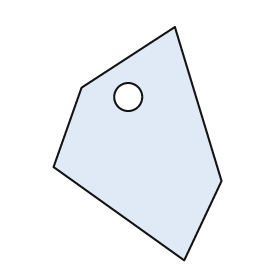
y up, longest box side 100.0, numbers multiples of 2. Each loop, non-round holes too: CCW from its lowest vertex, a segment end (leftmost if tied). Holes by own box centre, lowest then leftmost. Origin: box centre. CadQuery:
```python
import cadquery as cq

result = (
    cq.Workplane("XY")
    .moveTo(20.0, -50.0)
    .lineTo(36.0, -16.0)
    .lineTo(16.0, 50.0)
    .lineTo(-24.0, 24.0)
    .lineTo(-36.0, -10.0)
    .close()
    .moveTo(-4.0, 20.0)
    .circle(6.0)
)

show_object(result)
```